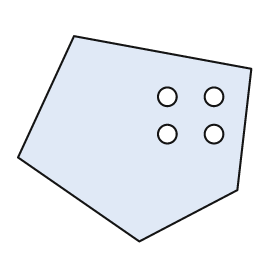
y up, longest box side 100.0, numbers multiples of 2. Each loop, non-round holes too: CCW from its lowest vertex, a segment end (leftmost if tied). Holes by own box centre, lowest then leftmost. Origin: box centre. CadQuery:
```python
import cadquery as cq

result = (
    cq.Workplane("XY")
    .moveTo(2.0, -44.0)
    .lineTo(44.0, -22.0)
    .lineTo(50.0, 30.0)
    .lineTo(-26.0, 44.0)
    .lineTo(-50.0, -8.0)
    .close()
    .moveTo(14.0, 2.0)
    .circle(4.0)
    .moveTo(34.0, 2.0)
    .circle(4.0)
    .moveTo(14.0, 18.0)
    .circle(4.0)
    .moveTo(34.0, 18.0)
    .circle(4.0)
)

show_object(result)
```